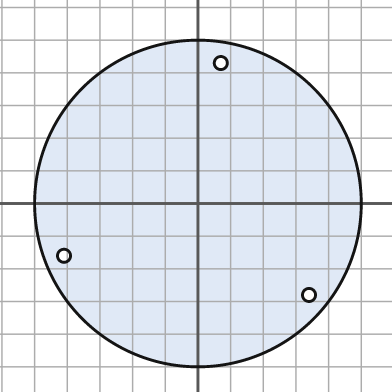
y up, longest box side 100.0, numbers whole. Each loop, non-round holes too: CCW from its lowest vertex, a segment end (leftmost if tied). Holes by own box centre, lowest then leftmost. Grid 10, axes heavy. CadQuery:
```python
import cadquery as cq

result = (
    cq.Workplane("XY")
    .moveTo(0.0, 0.0)
    .circle(50.0)
    .moveTo(34.0, -28.0)
    .circle(2.0)
    .moveTo(-41.0, -16.0)
    .circle(2.0)
    .moveTo(7.0, 43.0)
    .circle(2.0)
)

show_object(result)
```